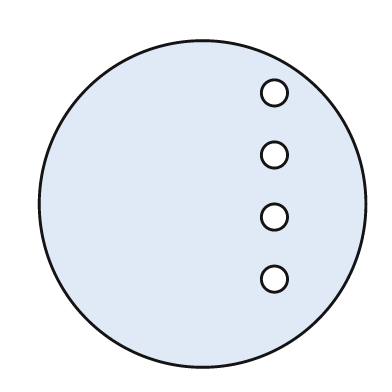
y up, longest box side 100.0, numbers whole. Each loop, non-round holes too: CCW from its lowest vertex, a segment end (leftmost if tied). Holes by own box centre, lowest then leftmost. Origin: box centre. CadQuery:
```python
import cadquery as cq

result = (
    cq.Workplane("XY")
    .moveTo(0.0, 0.0)
    .circle(50.0)
    .moveTo(22.0, -23.0)
    .circle(4.0)
    .moveTo(22.0, -4.0)
    .circle(4.0)
    .moveTo(22.0, 15.0)
    .circle(4.0)
    .moveTo(22.0, 34.0)
    .circle(4.0)
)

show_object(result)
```